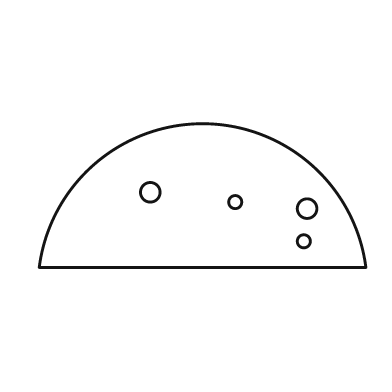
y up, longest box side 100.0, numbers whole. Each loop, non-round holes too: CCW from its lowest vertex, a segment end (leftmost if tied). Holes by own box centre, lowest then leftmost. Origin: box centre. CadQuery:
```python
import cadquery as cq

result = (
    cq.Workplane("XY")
    .moveTo(-50.0, -22.0)
    .lineTo(50.0, -22.0)
    .threePointArc((0.0, 22.0), (-50.0, -22.0))
    .close()
    .moveTo(31.0, -14.0)
    .circle(2.0)
    .moveTo(32.0, -4.0)
    .circle(3.0)
    .moveTo(10.0, -2.0)
    .circle(2.0)
    .moveTo(-16.0, 1.0)
    .circle(3.0)
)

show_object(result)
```